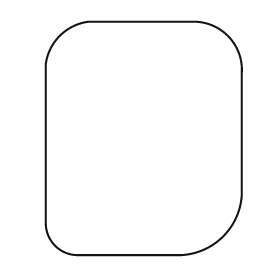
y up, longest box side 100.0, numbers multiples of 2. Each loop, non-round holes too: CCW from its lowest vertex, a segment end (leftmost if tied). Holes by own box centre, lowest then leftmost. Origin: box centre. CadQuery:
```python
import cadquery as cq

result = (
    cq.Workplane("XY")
    .moveTo(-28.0, -50.0)
    .lineTo(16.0, -50.0)
    .threePointArc((34.0, -42.0), (42.0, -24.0))
    .lineTo(42.0, 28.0)
    .threePointArc((36.0, 44.0), (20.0, 50.0))
    .lineTo(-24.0, 50.0)
    .threePointArc((-36.0, 44.0), (-42.0, 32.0))
    .lineTo(-42.0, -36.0)
    .threePointArc((-38.0, -46.0), (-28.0, -50.0))
    .close()
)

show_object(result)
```